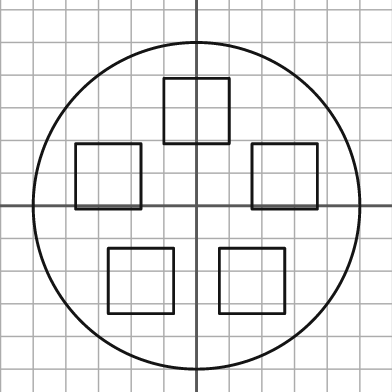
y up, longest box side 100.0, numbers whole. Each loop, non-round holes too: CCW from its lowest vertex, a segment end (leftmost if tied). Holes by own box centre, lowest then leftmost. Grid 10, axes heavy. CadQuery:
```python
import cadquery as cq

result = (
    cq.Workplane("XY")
    .moveTo(0.0, 0.0)
    .circle(50.0)
    .moveTo(-27.0, -33.0)
    .lineTo(-7.0, -33.0)
    .lineTo(-7.0, -13.0)
    .lineTo(-27.0, -13.0)
    .close()
    .moveTo(7.0, -33.0)
    .lineTo(27.0, -33.0)
    .lineTo(27.0, -13.0)
    .lineTo(7.0, -13.0)
    .close()
    .moveTo(-37.0, -1.0)
    .lineTo(-17.0, -1.0)
    .lineTo(-17.0, 19.0)
    .lineTo(-37.0, 19.0)
    .close()
    .moveTo(17.0, -1.0)
    .lineTo(37.0, -1.0)
    .lineTo(37.0, 19.0)
    .lineTo(17.0, 19.0)
    .close()
    .moveTo(-10.0, 19.0)
    .lineTo(10.0, 19.0)
    .lineTo(10.0, 39.0)
    .lineTo(-10.0, 39.0)
    .close()
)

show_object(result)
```